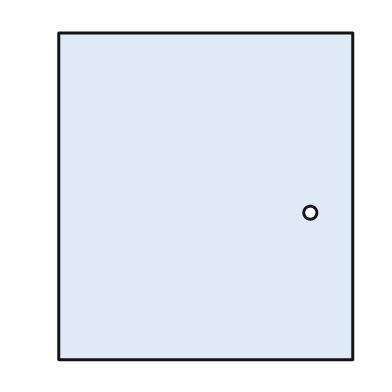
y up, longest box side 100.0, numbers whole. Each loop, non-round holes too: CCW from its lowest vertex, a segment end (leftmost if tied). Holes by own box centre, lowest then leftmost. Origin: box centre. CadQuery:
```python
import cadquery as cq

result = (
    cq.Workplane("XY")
    .moveTo(-45.0, -50.0)
    .lineTo(45.0, -50.0)
    .lineTo(45.0, 50.0)
    .lineTo(-45.0, 50.0)
    .close()
    .moveTo(32.0, -5.0)
    .circle(2.0)
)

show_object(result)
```